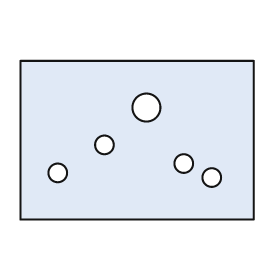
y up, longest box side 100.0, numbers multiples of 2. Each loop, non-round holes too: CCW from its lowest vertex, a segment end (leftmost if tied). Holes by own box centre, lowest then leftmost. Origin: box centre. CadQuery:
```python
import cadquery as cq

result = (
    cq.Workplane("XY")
    .moveTo(-50.0, -34.0)
    .lineTo(50.0, -34.0)
    .lineTo(50.0, 34.0)
    .lineTo(-50.0, 34.0)
    .close()
    .moveTo(32.0, -16.0)
    .circle(4.0)
    .moveTo(-34.0, -14.0)
    .circle(4.0)
    .moveTo(20.0, -10.0)
    .circle(4.0)
    .moveTo(-14.0, -2.0)
    .circle(4.0)
    .moveTo(4.0, 14.0)
    .circle(6.0)
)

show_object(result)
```